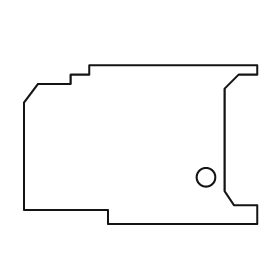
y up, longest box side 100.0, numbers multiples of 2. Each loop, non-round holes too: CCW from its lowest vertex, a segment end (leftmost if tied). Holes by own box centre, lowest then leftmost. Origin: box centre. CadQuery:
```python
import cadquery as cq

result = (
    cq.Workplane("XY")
    .moveTo(-14.0, -34.0)
    .lineTo(50.0, -34.0)
    .lineTo(50.0, -26.0)
    .lineTo(40.0, -26.0)
    .lineTo(36.0, -20.0)
    .lineTo(36.0, 24.0)
    .lineTo(42.0, 30.0)
    .lineTo(50.0, 30.0)
    .lineTo(50.0, 34.0)
    .lineTo(-22.0, 34.0)
    .lineTo(-22.0, 30.0)
    .lineTo(-30.0, 30.0)
    .lineTo(-30.0, 26.0)
    .lineTo(-44.0, 26.0)
    .lineTo(-50.0, 18.0)
    .lineTo(-50.0, -28.0)
    .lineTo(-14.0, -28.0)
    .close()
    .moveTo(28.0, -14.0)
    .circle(4.0)
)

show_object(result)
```